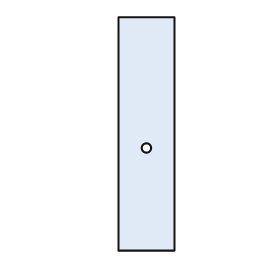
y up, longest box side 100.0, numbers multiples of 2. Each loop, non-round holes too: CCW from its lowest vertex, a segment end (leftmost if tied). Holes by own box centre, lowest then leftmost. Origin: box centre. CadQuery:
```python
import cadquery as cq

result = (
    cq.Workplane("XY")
    .moveTo(-12.0, -50.0)
    .lineTo(12.0, -50.0)
    .lineTo(12.0, 50.0)
    .lineTo(-12.0, 50.0)
    .close()
    .moveTo(0.0, -6.0)
    .circle(2.0)
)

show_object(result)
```